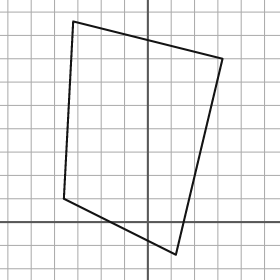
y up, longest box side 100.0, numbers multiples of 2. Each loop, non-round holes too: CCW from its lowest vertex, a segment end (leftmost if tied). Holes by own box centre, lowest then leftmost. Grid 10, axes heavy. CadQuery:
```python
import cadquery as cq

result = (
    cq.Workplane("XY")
    .moveTo(12.0, -14.0)
    .lineTo(32.0, 70.0)
    .lineTo(-32.0, 86.0)
    .lineTo(-36.0, 10.0)
    .close()
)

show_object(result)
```